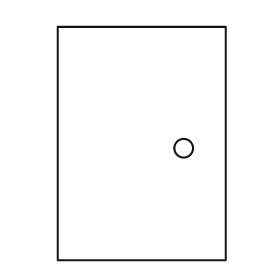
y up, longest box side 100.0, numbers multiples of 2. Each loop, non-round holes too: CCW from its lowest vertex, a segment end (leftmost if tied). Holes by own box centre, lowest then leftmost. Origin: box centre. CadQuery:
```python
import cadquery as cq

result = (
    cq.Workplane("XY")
    .moveTo(-36.0, -50.0)
    .lineTo(36.0, -50.0)
    .lineTo(36.0, 50.0)
    .lineTo(-36.0, 50.0)
    .close()
    .moveTo(18.0, -2.0)
    .circle(4.0)
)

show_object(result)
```